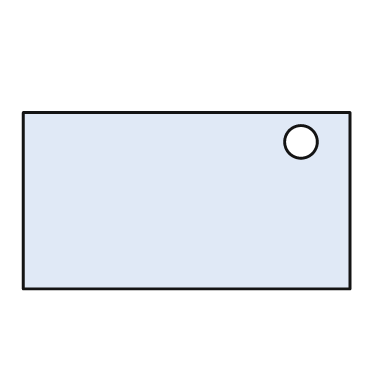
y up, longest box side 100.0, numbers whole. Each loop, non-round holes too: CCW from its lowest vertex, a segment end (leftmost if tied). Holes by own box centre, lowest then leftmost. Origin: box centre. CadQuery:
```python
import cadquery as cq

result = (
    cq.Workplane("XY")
    .moveTo(-50.0, -27.0)
    .lineTo(50.0, -27.0)
    .lineTo(50.0, 27.0)
    .lineTo(-50.0, 27.0)
    .close()
    .moveTo(35.0, 18.0)
    .circle(5.0)
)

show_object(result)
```